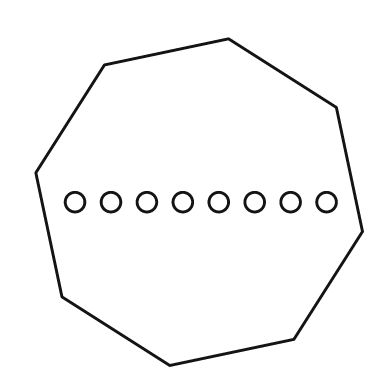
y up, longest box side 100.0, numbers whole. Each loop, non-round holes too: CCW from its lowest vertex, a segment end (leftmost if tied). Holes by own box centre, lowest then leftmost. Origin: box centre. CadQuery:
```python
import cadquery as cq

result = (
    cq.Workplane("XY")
    .moveTo(-9.0, -50.0)
    .lineTo(29.0, -42.0)
    .lineTo(50.0, -9.0)
    .lineTo(42.0, 29.0)
    .lineTo(9.0, 50.0)
    .lineTo(-29.0, 42.0)
    .lineTo(-50.0, 9.0)
    .lineTo(-42.0, -29.0)
    .close()
    .moveTo(-38.0, 0.0)
    .circle(3.0)
    .moveTo(-27.0, 0.0)
    .circle(3.0)
    .moveTo(-16.0, 0.0)
    .circle(3.0)
    .moveTo(-5.0, 0.0)
    .circle(3.0)
    .moveTo(6.0, 0.0)
    .circle(3.0)
    .moveTo(17.0, 0.0)
    .circle(3.0)
    .moveTo(28.0, 0.0)
    .circle(3.0)
    .moveTo(39.0, 0.0)
    .circle(3.0)
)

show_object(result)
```